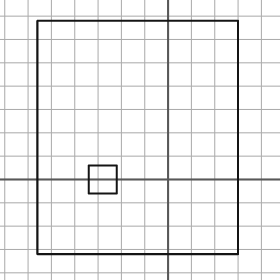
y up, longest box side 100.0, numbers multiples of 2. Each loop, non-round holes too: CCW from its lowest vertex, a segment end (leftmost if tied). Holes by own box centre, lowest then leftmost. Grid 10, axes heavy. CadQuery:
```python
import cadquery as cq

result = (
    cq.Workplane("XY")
    .moveTo(-56.0, -32.0)
    .lineTo(30.0, -32.0)
    .lineTo(30.0, 68.0)
    .lineTo(-56.0, 68.0)
    .close()
    .moveTo(-34.0, -6.0)
    .lineTo(-22.0, -6.0)
    .lineTo(-22.0, 6.0)
    .lineTo(-34.0, 6.0)
    .close()
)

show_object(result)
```